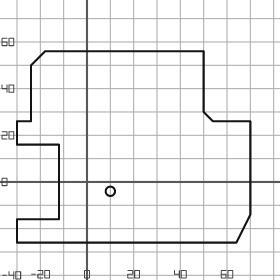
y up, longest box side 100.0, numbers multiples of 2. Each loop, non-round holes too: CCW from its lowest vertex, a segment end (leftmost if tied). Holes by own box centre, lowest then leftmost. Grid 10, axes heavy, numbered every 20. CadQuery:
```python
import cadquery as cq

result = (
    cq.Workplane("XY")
    .moveTo(-30.0, -26.0)
    .lineTo(64.0, -26.0)
    .lineTo(70.0, -14.0)
    .lineTo(70.0, 26.0)
    .lineTo(54.0, 26.0)
    .lineTo(50.0, 30.0)
    .lineTo(50.0, 56.0)
    .lineTo(-18.0, 56.0)
    .lineTo(-24.0, 50.0)
    .lineTo(-24.0, 26.0)
    .lineTo(-30.0, 26.0)
    .lineTo(-30.0, 16.0)
    .lineTo(-12.0, 16.0)
    .lineTo(-12.0, -16.0)
    .lineTo(-30.0, -16.0)
    .close()
    .moveTo(10.0, -4.0)
    .circle(2.0)
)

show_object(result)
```